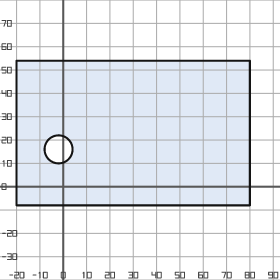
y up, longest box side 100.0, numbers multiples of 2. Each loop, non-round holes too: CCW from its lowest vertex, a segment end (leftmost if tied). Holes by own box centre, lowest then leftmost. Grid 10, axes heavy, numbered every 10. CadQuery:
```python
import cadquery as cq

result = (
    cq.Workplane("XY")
    .moveTo(-20.0, -8.0)
    .lineTo(80.0, -8.0)
    .lineTo(80.0, 54.0)
    .lineTo(-20.0, 54.0)
    .close()
    .moveTo(-2.0, 16.0)
    .circle(6.0)
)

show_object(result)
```